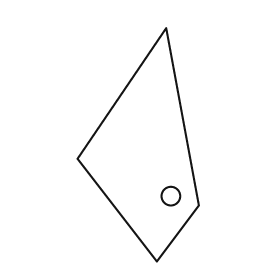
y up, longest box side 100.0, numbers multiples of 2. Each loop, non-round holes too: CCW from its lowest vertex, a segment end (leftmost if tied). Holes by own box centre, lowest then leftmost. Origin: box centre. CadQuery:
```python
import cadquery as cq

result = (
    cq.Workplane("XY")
    .moveTo(8.0, -50.0)
    .lineTo(26.0, -26.0)
    .lineTo(12.0, 50.0)
    .lineTo(-26.0, -6.0)
    .close()
    .moveTo(14.0, -22.0)
    .circle(4.0)
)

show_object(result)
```